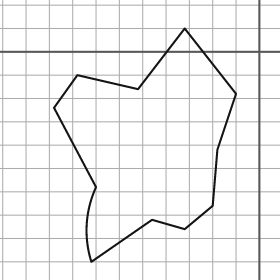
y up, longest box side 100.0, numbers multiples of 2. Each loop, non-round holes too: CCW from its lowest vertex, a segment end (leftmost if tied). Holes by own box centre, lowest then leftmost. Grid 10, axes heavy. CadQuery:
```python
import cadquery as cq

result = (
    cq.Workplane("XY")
    .moveTo(-72.0, -90.0)
    .lineTo(-46.0, -72.0)
    .lineTo(-32.0, -76.0)
    .lineTo(-20.0, -66.0)
    .lineTo(-18.0, -42.0)
    .lineTo(-10.0, -18.0)
    .lineTo(-32.0, 10.0)
    .lineTo(-52.0, -16.0)
    .lineTo(-78.0, -10.0)
    .lineTo(-88.0, -24.0)
    .lineTo(-70.0, -58.0)
    .threePointArc((-74.0, -74.0), (-72.0, -90.0))
    .close()
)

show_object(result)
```